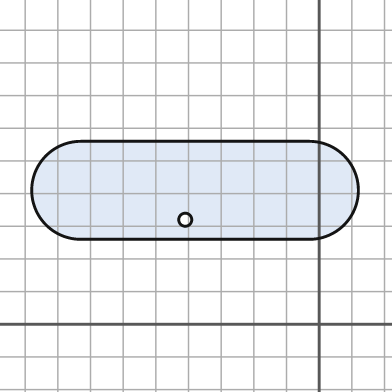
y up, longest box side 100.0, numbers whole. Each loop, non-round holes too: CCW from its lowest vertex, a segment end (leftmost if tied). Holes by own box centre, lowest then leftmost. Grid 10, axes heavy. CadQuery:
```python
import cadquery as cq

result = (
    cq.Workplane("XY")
    .moveTo(-73.0, 26.0)
    .lineTo(-3.0, 26.0)
    .threePointArc((12.0, 41.0), (-3.0, 56.0))
    .lineTo(-73.0, 56.0)
    .threePointArc((-88.0, 41.0), (-73.0, 26.0))
    .close()
    .moveTo(-41.0, 32.0)
    .circle(2.0)
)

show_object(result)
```